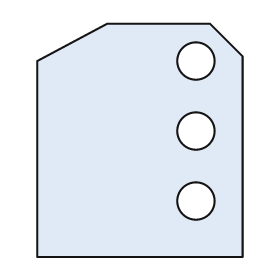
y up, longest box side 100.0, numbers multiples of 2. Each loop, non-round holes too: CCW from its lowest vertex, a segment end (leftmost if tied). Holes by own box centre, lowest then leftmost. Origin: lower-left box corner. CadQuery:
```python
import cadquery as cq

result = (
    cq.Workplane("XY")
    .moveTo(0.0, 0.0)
    .lineTo(88.0, 0.0)
    .lineTo(88.0, 86.0)
    .lineTo(74.0, 100.0)
    .lineTo(30.0, 100.0)
    .lineTo(0.0, 84.0)
    .close()
    .moveTo(68.0, 24.0)
    .circle(8.0)
    .moveTo(68.0, 54.0)
    .circle(8.0)
    .moveTo(68.0, 84.0)
    .circle(8.0)
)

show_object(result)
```